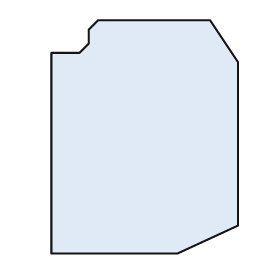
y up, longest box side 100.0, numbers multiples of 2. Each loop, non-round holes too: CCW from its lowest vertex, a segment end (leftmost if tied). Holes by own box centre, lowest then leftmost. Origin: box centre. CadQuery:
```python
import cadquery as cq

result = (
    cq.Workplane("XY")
    .moveTo(-40.0, -50.0)
    .lineTo(14.0, -50.0)
    .lineTo(40.0, -38.0)
    .lineTo(40.0, 32.0)
    .lineTo(28.0, 50.0)
    .lineTo(-20.0, 50.0)
    .lineTo(-24.0, 46.0)
    .lineTo(-24.0, 40.0)
    .lineTo(-28.0, 36.0)
    .lineTo(-40.0, 36.0)
    .close()
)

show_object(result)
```